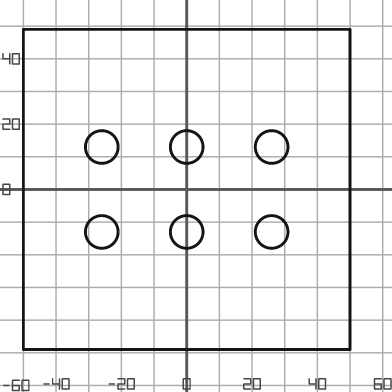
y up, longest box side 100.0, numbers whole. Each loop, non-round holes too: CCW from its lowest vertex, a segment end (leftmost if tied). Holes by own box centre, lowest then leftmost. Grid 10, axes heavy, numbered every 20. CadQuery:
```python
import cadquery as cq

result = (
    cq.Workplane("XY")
    .moveTo(-50.0, -49.0)
    .lineTo(50.0, -49.0)
    .lineTo(50.0, 49.0)
    .lineTo(-50.0, 49.0)
    .close()
    .moveTo(-26.0, -13.0)
    .circle(5.0)
    .moveTo(0.0, -13.0)
    .circle(5.0)
    .moveTo(26.0, -13.0)
    .circle(5.0)
    .moveTo(-26.0, 13.0)
    .circle(5.0)
    .moveTo(0.0, 13.0)
    .circle(5.0)
    .moveTo(26.0, 13.0)
    .circle(5.0)
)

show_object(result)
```